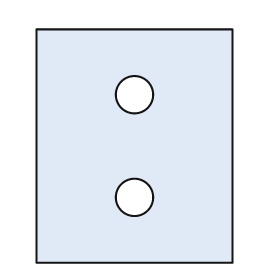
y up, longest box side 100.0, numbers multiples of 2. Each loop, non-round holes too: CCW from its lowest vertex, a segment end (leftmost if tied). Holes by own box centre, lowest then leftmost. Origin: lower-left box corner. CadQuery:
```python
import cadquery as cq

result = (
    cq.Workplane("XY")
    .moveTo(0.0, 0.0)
    .lineTo(84.0, 0.0)
    .lineTo(84.0, 100.0)
    .lineTo(0.0, 100.0)
    .close()
    .moveTo(42.0, 28.0)
    .circle(8.0)
    .moveTo(42.0, 72.0)
    .circle(8.0)
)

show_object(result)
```